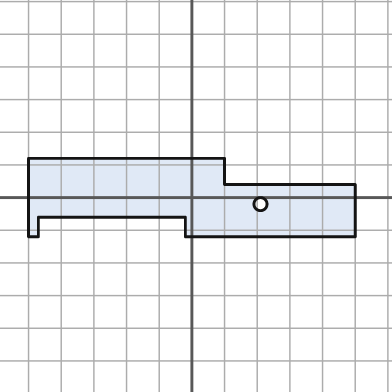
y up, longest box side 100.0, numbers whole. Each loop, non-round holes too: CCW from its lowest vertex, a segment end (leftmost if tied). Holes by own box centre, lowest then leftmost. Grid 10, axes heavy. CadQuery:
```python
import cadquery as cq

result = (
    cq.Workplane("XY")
    .moveTo(-50.0, -12.0)
    .lineTo(-47.0, -12.0)
    .lineTo(-47.0, -6.0)
    .lineTo(-2.0, -6.0)
    .lineTo(-2.0, -12.0)
    .lineTo(50.0, -12.0)
    .lineTo(50.0, 4.0)
    .lineTo(10.0, 4.0)
    .lineTo(10.0, 12.0)
    .lineTo(-50.0, 12.0)
    .close()
    .moveTo(21.0, -2.0)
    .circle(2.0)
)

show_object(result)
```